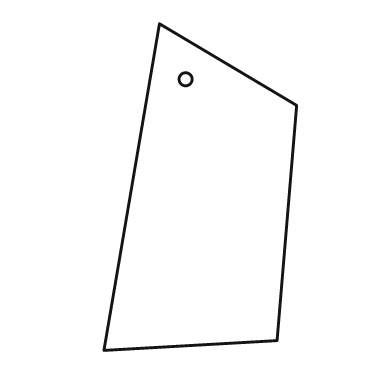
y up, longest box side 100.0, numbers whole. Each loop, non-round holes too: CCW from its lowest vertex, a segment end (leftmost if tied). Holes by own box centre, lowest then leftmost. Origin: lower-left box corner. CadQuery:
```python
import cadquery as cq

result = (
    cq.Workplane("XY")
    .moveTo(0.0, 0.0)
    .lineTo(53.0, 3.0)
    .lineTo(59.0, 75.0)
    .lineTo(17.0, 100.0)
    .close()
    .moveTo(25.0, 83.0)
    .circle(2.0)
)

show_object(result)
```